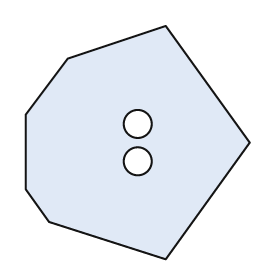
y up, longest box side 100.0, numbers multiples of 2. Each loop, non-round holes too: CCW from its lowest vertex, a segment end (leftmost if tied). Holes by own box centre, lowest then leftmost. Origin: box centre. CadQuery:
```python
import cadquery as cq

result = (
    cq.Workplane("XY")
    .moveTo(12.0, -50.0)
    .lineTo(48.0, 0.0)
    .lineTo(12.0, 50.0)
    .lineTo(-30.0, 36.0)
    .lineTo(-48.0, 12.0)
    .lineTo(-48.0, -20.0)
    .lineTo(-38.0, -34.0)
    .close()
    .moveTo(0.0, -8.0)
    .circle(6.0)
    .moveTo(0.0, 8.0)
    .circle(6.0)
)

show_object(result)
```